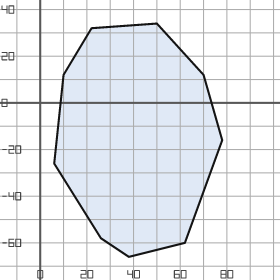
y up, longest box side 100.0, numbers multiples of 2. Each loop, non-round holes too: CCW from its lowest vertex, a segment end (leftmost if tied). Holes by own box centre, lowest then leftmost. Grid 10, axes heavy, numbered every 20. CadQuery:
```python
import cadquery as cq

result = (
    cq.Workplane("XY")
    .moveTo(38.0, -66.0)
    .lineTo(62.0, -60.0)
    .lineTo(78.0, -16.0)
    .lineTo(70.0, 12.0)
    .lineTo(50.0, 34.0)
    .lineTo(22.0, 32.0)
    .lineTo(10.0, 12.0)
    .lineTo(6.0, -26.0)
    .lineTo(26.0, -58.0)
    .close()
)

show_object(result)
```